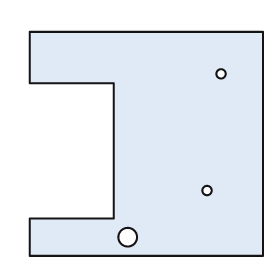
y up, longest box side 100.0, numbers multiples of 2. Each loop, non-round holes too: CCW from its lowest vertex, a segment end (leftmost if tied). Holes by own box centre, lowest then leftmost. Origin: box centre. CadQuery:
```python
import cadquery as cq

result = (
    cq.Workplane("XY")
    .moveTo(-50.0, -48.0)
    .lineTo(50.0, -48.0)
    .lineTo(50.0, 48.0)
    .lineTo(-50.0, 48.0)
    .lineTo(-50.0, 26.0)
    .lineTo(-14.0, 26.0)
    .lineTo(-14.0, -32.0)
    .lineTo(-50.0, -32.0)
    .close()
    .moveTo(-8.0, -40.0)
    .circle(4.0)
    .moveTo(26.0, -20.0)
    .circle(2.0)
    .moveTo(32.0, 30.0)
    .circle(2.0)
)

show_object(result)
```